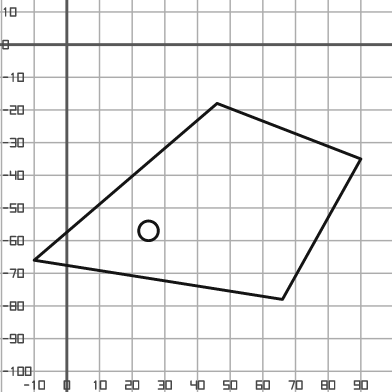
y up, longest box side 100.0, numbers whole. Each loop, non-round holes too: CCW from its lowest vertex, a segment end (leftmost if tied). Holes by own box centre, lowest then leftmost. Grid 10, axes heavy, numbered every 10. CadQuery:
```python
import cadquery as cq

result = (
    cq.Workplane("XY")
    .moveTo(66.0, -78.0)
    .lineTo(90.0, -35.0)
    .lineTo(46.0, -18.0)
    .lineTo(-10.0, -66.0)
    .close()
    .moveTo(25.0, -57.0)
    .circle(3.0)
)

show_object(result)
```